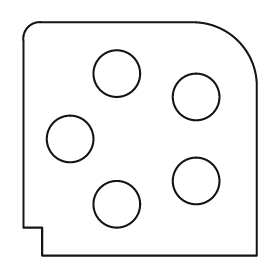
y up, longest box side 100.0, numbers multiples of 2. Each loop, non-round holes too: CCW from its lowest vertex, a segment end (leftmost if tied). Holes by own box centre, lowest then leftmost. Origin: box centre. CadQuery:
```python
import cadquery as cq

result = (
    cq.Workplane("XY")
    .moveTo(-42.0, -50.0)
    .lineTo(50.0, -50.0)
    .lineTo(50.0, 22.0)
    .threePointArc((42.0, 42.0), (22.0, 50.0))
    .lineTo(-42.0, 50.0)
    .threePointArc((-48.0, 48.0), (-50.0, 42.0))
    .lineTo(-50.0, -38.0)
    .lineTo(-42.0, -38.0)
    .close()
    .moveTo(-10.0, -28.0)
    .circle(10.0)
    .moveTo(24.0, -18.0)
    .circle(10.0)
    .moveTo(-30.0, 0.0)
    .circle(10.0)
    .moveTo(24.0, 18.0)
    .circle(10.0)
    .moveTo(-10.0, 28.0)
    .circle(10.0)
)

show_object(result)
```